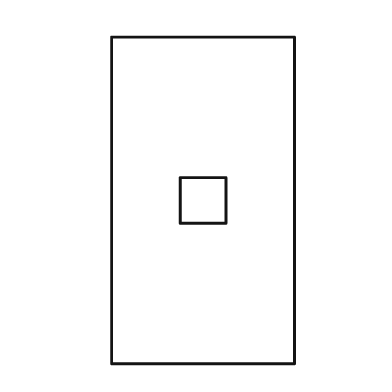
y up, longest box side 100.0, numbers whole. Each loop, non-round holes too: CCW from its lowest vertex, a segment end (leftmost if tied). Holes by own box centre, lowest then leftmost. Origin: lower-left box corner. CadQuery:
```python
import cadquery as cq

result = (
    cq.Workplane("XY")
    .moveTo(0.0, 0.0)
    .lineTo(56.0, 0.0)
    .lineTo(56.0, 100.0)
    .lineTo(0.0, 100.0)
    .close()
    .moveTo(21.0, 43.0)
    .lineTo(35.0, 43.0)
    .lineTo(35.0, 57.0)
    .lineTo(21.0, 57.0)
    .close()
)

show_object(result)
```